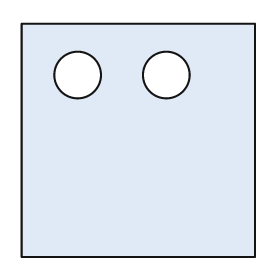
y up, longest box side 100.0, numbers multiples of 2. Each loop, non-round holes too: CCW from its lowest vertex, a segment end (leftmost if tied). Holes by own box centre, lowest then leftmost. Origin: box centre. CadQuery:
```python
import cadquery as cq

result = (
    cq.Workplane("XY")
    .moveTo(-50.0, -50.0)
    .lineTo(50.0, -50.0)
    .lineTo(50.0, 50.0)
    .lineTo(-50.0, 50.0)
    .close()
    .moveTo(-26.0, 28.0)
    .circle(10.0)
    .moveTo(12.0, 28.0)
    .circle(10.0)
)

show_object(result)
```